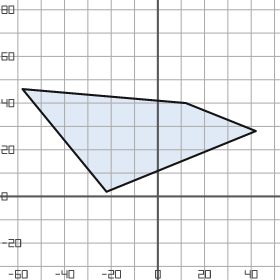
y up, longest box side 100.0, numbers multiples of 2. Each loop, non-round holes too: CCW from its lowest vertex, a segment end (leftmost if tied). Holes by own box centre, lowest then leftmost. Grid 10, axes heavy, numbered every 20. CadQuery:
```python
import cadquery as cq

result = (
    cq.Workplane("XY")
    .moveTo(-22.0, 2.0)
    .lineTo(42.0, 28.0)
    .lineTo(12.0, 40.0)
    .lineTo(-58.0, 46.0)
    .close()
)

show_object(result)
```